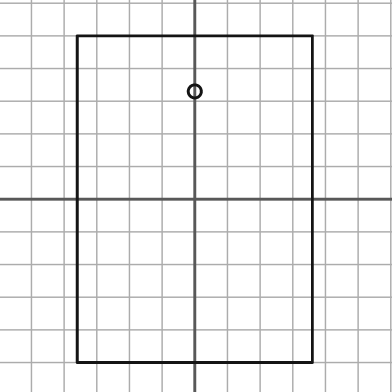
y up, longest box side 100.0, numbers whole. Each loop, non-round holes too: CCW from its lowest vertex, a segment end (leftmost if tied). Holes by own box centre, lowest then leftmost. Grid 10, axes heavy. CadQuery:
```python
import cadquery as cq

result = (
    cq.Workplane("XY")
    .moveTo(-36.0, -50.0)
    .lineTo(36.0, -50.0)
    .lineTo(36.0, 50.0)
    .lineTo(-36.0, 50.0)
    .close()
    .moveTo(0.0, 33.0)
    .circle(2.0)
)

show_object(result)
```